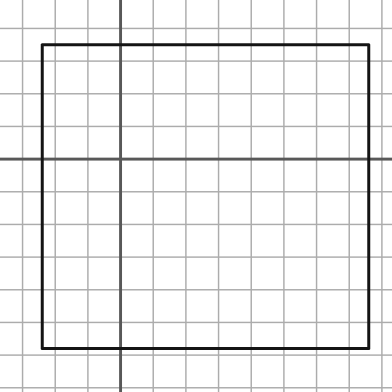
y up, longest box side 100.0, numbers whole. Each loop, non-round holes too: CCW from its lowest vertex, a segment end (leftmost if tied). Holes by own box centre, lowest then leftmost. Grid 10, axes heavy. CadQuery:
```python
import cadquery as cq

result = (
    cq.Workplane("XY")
    .moveTo(-24.0, -58.0)
    .lineTo(76.0, -58.0)
    .lineTo(76.0, 35.0)
    .lineTo(-24.0, 35.0)
    .close()
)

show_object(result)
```